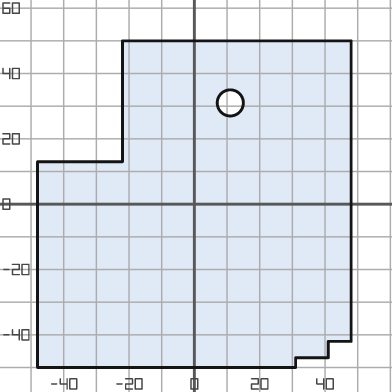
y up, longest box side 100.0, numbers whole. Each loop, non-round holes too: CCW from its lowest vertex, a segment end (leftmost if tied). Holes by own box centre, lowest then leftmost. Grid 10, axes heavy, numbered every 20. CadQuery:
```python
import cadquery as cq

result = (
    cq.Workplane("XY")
    .moveTo(-48.0, -50.0)
    .lineTo(31.0, -50.0)
    .lineTo(31.0, -47.0)
    .lineTo(41.0, -47.0)
    .lineTo(41.0, -42.0)
    .lineTo(48.0, -42.0)
    .lineTo(48.0, 50.0)
    .lineTo(-22.0, 50.0)
    .lineTo(-22.0, 13.0)
    .lineTo(-48.0, 13.0)
    .close()
    .moveTo(11.0, 31.0)
    .circle(4.0)
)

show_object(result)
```